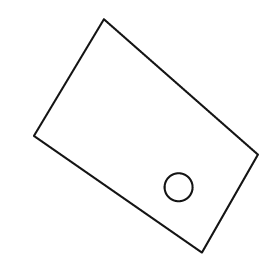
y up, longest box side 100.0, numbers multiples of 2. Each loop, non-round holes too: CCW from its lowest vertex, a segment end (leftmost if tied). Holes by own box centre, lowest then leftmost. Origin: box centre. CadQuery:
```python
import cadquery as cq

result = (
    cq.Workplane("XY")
    .moveTo(24.0, -50.0)
    .lineTo(48.0, -8.0)
    .lineTo(-18.0, 50.0)
    .lineTo(-48.0, 0.0)
    .close()
    .moveTo(14.0, -22.0)
    .circle(6.0)
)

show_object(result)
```